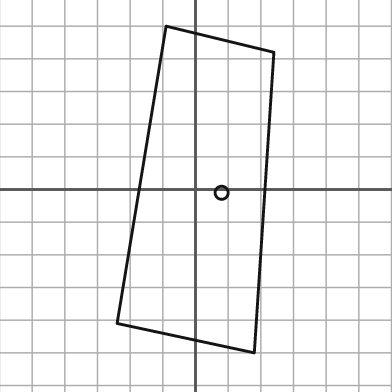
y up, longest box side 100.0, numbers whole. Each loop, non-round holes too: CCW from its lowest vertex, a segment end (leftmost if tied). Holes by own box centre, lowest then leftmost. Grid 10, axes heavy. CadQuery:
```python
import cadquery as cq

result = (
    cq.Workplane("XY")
    .moveTo(18.0, -50.0)
    .lineTo(24.0, 42.0)
    .lineTo(-9.0, 50.0)
    .lineTo(-24.0, -41.0)
    .close()
    .moveTo(8.0, -1.0)
    .circle(2.0)
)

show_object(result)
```